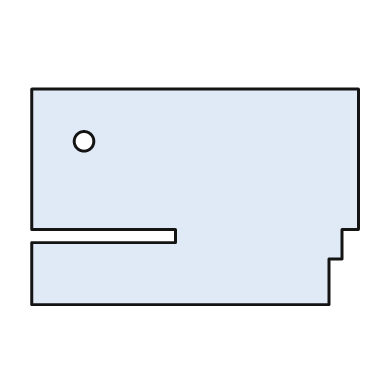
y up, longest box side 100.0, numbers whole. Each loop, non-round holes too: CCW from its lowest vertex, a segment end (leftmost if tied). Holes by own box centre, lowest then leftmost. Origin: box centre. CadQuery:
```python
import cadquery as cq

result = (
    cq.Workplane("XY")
    .moveTo(-50.0, -33.0)
    .lineTo(41.0, -33.0)
    .lineTo(41.0, -19.0)
    .lineTo(45.0, -19.0)
    .lineTo(45.0, -10.0)
    .lineTo(50.0, -10.0)
    .lineTo(50.0, 33.0)
    .lineTo(-50.0, 33.0)
    .lineTo(-50.0, -10.0)
    .lineTo(-6.0, -10.0)
    .lineTo(-6.0, -14.0)
    .lineTo(-50.0, -14.0)
    .close()
    .moveTo(-34.0, 17.0)
    .circle(3.0)
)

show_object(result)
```